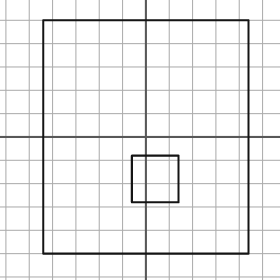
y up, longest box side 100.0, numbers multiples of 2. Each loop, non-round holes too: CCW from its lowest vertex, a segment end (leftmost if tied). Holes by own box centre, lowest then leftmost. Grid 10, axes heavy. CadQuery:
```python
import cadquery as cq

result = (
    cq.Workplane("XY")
    .moveTo(-44.0, -50.0)
    .lineTo(44.0, -50.0)
    .lineTo(44.0, 50.0)
    .lineTo(-44.0, 50.0)
    .close()
    .moveTo(-6.0, -28.0)
    .lineTo(14.0, -28.0)
    .lineTo(14.0, -8.0)
    .lineTo(-6.0, -8.0)
    .close()
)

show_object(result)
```